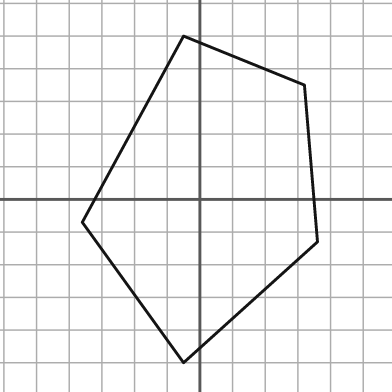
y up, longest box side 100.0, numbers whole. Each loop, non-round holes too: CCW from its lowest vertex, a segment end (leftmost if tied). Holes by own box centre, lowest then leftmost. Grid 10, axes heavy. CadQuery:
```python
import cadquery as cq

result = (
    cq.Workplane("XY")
    .moveTo(-5.0, -50.0)
    .lineTo(36.0, -13.0)
    .lineTo(32.0, 35.0)
    .lineTo(-5.0, 50.0)
    .lineTo(-36.0, -7.0)
    .close()
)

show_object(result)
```